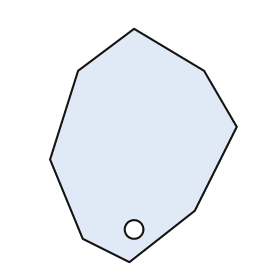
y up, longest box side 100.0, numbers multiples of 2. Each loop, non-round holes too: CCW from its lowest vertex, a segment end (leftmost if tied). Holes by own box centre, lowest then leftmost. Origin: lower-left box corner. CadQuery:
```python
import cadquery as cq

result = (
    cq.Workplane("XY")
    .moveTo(34.0, 0.0)
    .lineTo(62.0, 22.0)
    .lineTo(80.0, 58.0)
    .lineTo(66.0, 82.0)
    .lineTo(36.0, 100.0)
    .lineTo(12.0, 82.0)
    .lineTo(0.0, 44.0)
    .lineTo(14.0, 10.0)
    .close()
    .moveTo(36.0, 14.0)
    .circle(4.0)
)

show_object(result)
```